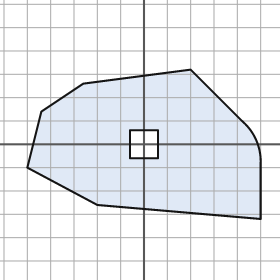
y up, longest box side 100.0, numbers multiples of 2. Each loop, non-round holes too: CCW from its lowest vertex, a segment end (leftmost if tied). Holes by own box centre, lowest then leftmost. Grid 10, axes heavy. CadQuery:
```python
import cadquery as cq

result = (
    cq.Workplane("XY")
    .moveTo(50.0, -32.0)
    .lineTo(50.0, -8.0)
    .threePointArc((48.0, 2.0), (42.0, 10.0))
    .lineTo(20.0, 32.0)
    .lineTo(-26.0, 26.0)
    .lineTo(-44.0, 14.0)
    .lineTo(-50.0, -10.0)
    .lineTo(-20.0, -26.0)
    .close()
    .moveTo(-6.0, -6.0)
    .lineTo(6.0, -6.0)
    .lineTo(6.0, 6.0)
    .lineTo(-6.0, 6.0)
    .close()
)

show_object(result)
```